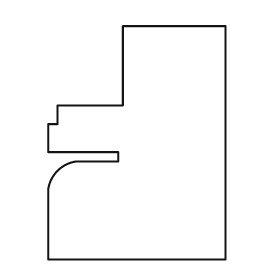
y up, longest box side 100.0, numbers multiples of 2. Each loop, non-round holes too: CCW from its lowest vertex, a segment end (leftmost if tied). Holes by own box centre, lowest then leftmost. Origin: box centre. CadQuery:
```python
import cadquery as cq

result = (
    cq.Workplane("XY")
    .moveTo(-38.0, -50.0)
    .lineTo(38.0, -50.0)
    .lineTo(38.0, 50.0)
    .lineTo(-6.0, 50.0)
    .lineTo(-6.0, 16.0)
    .lineTo(-34.0, 16.0)
    .lineTo(-34.0, 8.0)
    .lineTo(-38.0, 8.0)
    .lineTo(-38.0, -4.0)
    .lineTo(-8.0, -4.0)
    .lineTo(-8.0, -8.0)
    .lineTo(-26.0, -8.0)
    .threePointArc((-34.0, -12.0), (-38.0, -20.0))
    .close()
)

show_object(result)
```